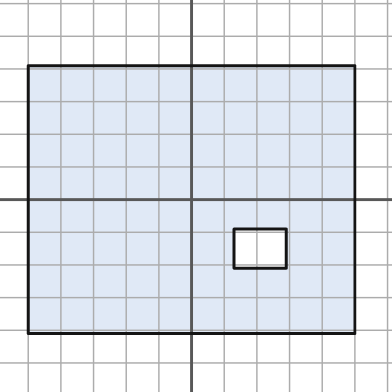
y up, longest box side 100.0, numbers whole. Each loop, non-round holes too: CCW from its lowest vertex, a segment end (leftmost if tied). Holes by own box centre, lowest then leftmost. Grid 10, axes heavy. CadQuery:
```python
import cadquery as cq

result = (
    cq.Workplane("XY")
    .moveTo(-50.0, -41.0)
    .lineTo(50.0, -41.0)
    .lineTo(50.0, 41.0)
    .lineTo(-50.0, 41.0)
    .close()
    .moveTo(13.0, -21.0)
    .lineTo(29.0, -21.0)
    .lineTo(29.0, -9.0)
    .lineTo(13.0, -9.0)
    .close()
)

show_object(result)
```